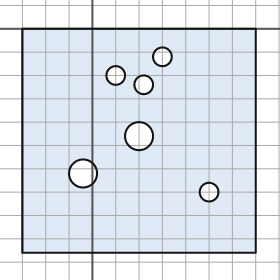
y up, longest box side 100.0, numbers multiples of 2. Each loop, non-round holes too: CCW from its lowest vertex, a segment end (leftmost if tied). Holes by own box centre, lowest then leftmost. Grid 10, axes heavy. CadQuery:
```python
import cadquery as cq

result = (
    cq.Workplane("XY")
    .moveTo(-30.0, -96.0)
    .lineTo(70.0, -96.0)
    .lineTo(70.0, 0.0)
    .lineTo(-30.0, 0.0)
    .close()
    .moveTo(50.0, -70.0)
    .circle(4.0)
    .moveTo(-4.0, -62.0)
    .circle(6.0)
    .moveTo(20.0, -46.0)
    .circle(6.0)
    .moveTo(22.0, -24.0)
    .circle(4.0)
    .moveTo(10.0, -20.0)
    .circle(4.0)
    .moveTo(30.0, -12.0)
    .circle(4.0)
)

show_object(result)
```